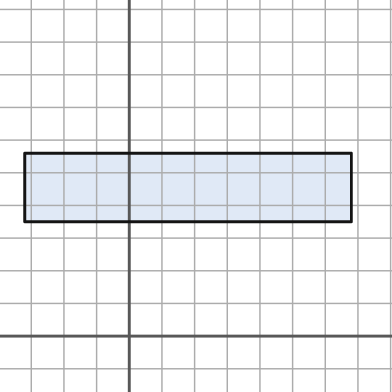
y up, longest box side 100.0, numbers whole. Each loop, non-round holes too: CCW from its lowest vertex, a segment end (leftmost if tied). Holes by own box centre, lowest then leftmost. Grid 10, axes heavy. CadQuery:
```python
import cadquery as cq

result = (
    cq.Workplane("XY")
    .moveTo(-32.0, 35.0)
    .lineTo(68.0, 35.0)
    .lineTo(68.0, 56.0)
    .lineTo(-32.0, 56.0)
    .close()
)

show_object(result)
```